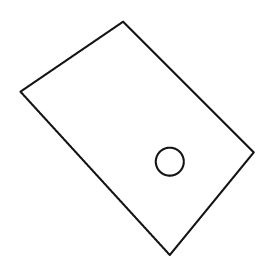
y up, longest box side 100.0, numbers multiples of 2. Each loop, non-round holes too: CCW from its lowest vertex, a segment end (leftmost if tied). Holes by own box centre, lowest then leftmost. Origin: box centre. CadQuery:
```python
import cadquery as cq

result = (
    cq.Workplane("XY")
    .moveTo(14.0, -50.0)
    .lineTo(50.0, -6.0)
    .lineTo(-6.0, 50.0)
    .lineTo(-50.0, 20.0)
    .close()
    .moveTo(14.0, -10.0)
    .circle(6.0)
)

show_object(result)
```